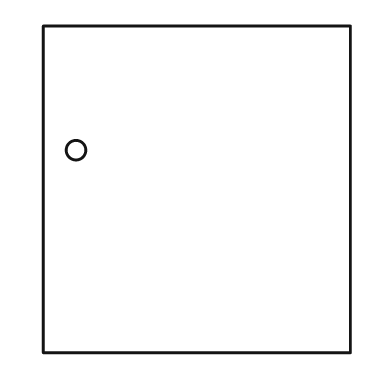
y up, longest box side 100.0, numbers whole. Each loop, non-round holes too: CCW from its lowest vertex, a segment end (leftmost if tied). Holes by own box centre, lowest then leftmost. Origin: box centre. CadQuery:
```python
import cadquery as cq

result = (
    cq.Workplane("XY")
    .moveTo(-47.0, -50.0)
    .lineTo(47.0, -50.0)
    .lineTo(47.0, 50.0)
    .lineTo(-47.0, 50.0)
    .close()
    .moveTo(-37.0, 12.0)
    .circle(3.0)
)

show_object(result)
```